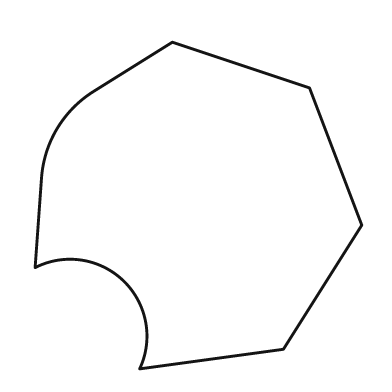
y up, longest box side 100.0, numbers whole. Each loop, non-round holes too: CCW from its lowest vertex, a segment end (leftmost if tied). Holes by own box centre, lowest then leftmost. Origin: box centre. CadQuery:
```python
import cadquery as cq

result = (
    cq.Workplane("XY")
    .moveTo(-18.0, -50.0)
    .lineTo(26.0, -44.0)
    .lineTo(50.0, -6.0)
    .lineTo(34.0, 36.0)
    .lineTo(-8.0, 50.0)
    .lineTo(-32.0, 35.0)
    .threePointArc((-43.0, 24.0), (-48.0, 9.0))
    .lineTo(-50.0, -19.0)
    .threePointArc((-23.0, -23.0), (-18.0, -50.0))
    .close()
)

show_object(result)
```